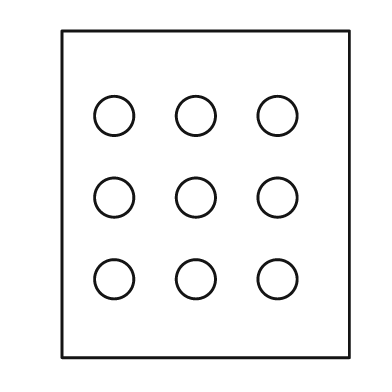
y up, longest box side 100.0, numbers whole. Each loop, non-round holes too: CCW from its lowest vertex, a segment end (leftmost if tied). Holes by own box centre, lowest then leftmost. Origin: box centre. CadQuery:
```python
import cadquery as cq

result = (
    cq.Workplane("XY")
    .moveTo(-44.0, -50.0)
    .lineTo(44.0, -50.0)
    .lineTo(44.0, 50.0)
    .lineTo(-44.0, 50.0)
    .close()
    .moveTo(-28.0, -26.0)
    .circle(6.0)
    .moveTo(-3.0, -26.0)
    .circle(6.0)
    .moveTo(22.0, -26.0)
    .circle(6.0)
    .moveTo(-28.0, -1.0)
    .circle(6.0)
    .moveTo(-3.0, -1.0)
    .circle(6.0)
    .moveTo(22.0, -1.0)
    .circle(6.0)
    .moveTo(-28.0, 24.0)
    .circle(6.0)
    .moveTo(-3.0, 24.0)
    .circle(6.0)
    .moveTo(22.0, 24.0)
    .circle(6.0)
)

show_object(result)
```